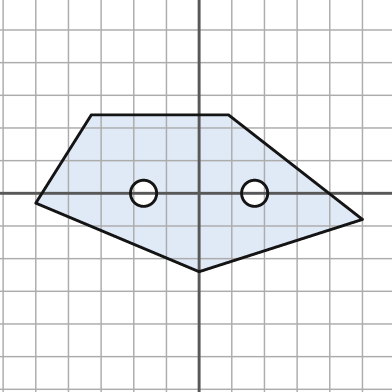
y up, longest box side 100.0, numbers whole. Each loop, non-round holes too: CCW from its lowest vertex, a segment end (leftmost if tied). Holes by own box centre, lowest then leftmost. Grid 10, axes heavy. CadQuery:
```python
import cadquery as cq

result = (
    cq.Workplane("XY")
    .moveTo(0.0, -24.0)
    .lineTo(50.0, -8.0)
    .lineTo(9.0, 24.0)
    .lineTo(-33.0, 24.0)
    .lineTo(-50.0, -3.0)
    .close()
    .moveTo(-17.0, 0.0)
    .circle(4.0)
    .moveTo(17.0, 0.0)
    .circle(4.0)
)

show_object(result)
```